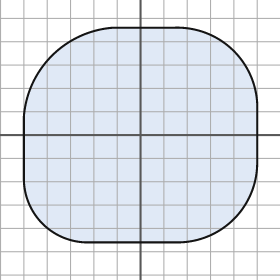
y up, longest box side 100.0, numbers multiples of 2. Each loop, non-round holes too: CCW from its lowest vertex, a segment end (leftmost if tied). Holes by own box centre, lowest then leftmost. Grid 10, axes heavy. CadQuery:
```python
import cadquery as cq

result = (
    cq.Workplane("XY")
    .moveTo(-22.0, -46.0)
    .lineTo(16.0, -46.0)
    .threePointArc((40.0, -36.0), (50.0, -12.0))
    .lineTo(50.0, 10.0)
    .threePointArc((40.0, 36.0), (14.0, 46.0))
    .lineTo(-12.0, 46.0)
    .threePointArc((-38.0, 34.0), (-50.0, 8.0))
    .lineTo(-50.0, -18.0)
    .threePointArc((-42.0, -38.0), (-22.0, -46.0))
    .close()
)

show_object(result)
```